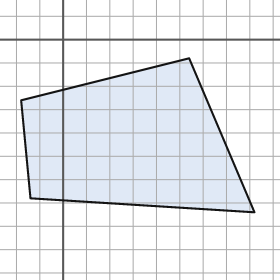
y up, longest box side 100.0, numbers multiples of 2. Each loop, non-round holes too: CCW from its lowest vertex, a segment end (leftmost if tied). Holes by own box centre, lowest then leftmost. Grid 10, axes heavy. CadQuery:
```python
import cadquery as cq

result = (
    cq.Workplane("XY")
    .moveTo(82.0, -74.0)
    .lineTo(54.0, -8.0)
    .lineTo(-18.0, -26.0)
    .lineTo(-14.0, -68.0)
    .close()
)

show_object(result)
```